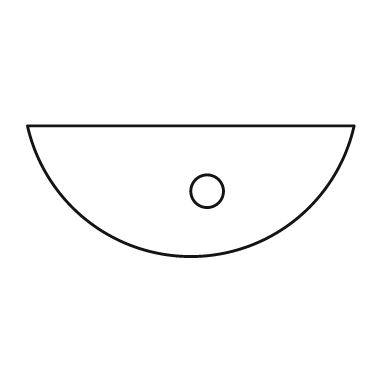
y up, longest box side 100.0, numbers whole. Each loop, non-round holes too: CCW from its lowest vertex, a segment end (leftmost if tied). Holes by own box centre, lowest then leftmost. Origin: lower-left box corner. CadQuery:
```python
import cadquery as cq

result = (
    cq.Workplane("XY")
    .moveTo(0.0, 40.0)
    .threePointArc((50.0, 0.0), (100.0, 40.0))
    .close()
    .moveTo(55.0, 20.0)
    .circle(5.0)
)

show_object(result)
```